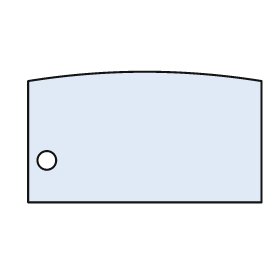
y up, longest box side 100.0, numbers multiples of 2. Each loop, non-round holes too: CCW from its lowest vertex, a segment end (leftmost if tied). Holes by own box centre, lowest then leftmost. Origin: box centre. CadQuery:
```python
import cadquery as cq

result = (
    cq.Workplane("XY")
    .moveTo(-50.0, -28.0)
    .lineTo(50.0, -28.0)
    .lineTo(50.0, 24.0)
    .threePointArc((0.0, 28.0), (-50.0, 24.0))
    .close()
    .moveTo(-42.0, -10.0)
    .circle(4.0)
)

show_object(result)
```